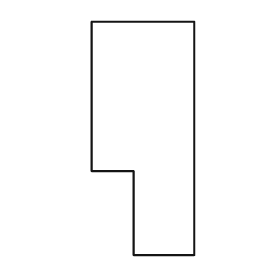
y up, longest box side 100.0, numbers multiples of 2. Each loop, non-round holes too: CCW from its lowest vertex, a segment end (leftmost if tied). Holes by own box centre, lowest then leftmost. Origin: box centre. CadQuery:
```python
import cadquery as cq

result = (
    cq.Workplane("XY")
    .moveTo(-4.0, -50.0)
    .lineTo(22.0, -50.0)
    .lineTo(22.0, 50.0)
    .lineTo(-22.0, 50.0)
    .lineTo(-22.0, -14.0)
    .lineTo(-4.0, -14.0)
    .close()
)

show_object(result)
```